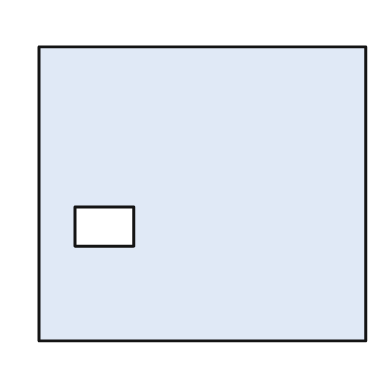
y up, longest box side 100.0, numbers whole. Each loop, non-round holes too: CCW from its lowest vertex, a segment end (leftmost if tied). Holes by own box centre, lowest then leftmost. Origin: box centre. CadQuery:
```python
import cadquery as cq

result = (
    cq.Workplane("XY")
    .moveTo(-50.0, -45.0)
    .lineTo(50.0, -45.0)
    .lineTo(50.0, 45.0)
    .lineTo(-50.0, 45.0)
    .close()
    .moveTo(-39.0, -16.0)
    .lineTo(-21.0, -16.0)
    .lineTo(-21.0, -4.0)
    .lineTo(-39.0, -4.0)
    .close()
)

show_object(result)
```